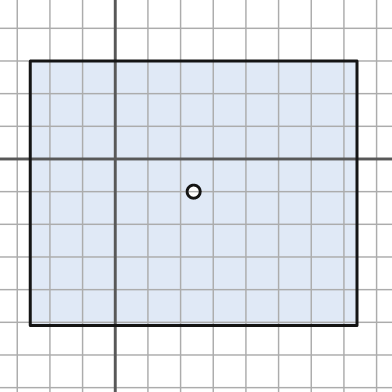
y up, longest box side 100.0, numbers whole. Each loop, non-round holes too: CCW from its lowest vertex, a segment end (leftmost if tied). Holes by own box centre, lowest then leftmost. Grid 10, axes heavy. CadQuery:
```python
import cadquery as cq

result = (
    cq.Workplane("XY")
    .moveTo(-26.0, -51.0)
    .lineTo(74.0, -51.0)
    .lineTo(74.0, 30.0)
    .lineTo(-26.0, 30.0)
    .close()
    .moveTo(24.0, -10.0)
    .circle(2.0)
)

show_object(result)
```